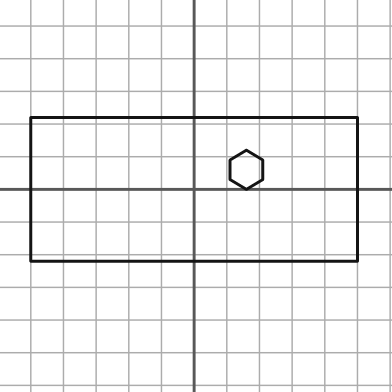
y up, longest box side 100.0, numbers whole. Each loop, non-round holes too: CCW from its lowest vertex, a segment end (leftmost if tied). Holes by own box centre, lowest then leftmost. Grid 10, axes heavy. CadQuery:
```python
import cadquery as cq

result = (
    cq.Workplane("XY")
    .moveTo(-50.0, -22.0)
    .lineTo(50.0, -22.0)
    .lineTo(50.0, 22.0)
    .lineTo(-50.0, 22.0)
    .close()
    .moveTo(16.0, 0.0)
    .lineTo(21.0, 3.0)
    .lineTo(21.0, 9.0)
    .lineTo(16.0, 12.0)
    .lineTo(11.0, 9.0)
    .lineTo(11.0, 3.0)
    .close()
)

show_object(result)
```